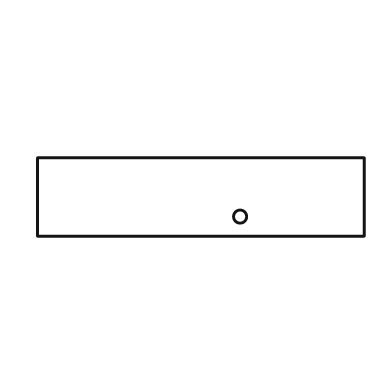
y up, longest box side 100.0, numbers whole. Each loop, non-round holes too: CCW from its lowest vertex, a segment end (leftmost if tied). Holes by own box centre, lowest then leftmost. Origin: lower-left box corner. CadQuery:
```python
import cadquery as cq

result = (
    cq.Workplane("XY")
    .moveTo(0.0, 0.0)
    .lineTo(100.0, 0.0)
    .lineTo(100.0, 24.0)
    .lineTo(0.0, 24.0)
    .close()
    .moveTo(62.0, 6.0)
    .circle(2.0)
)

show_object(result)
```